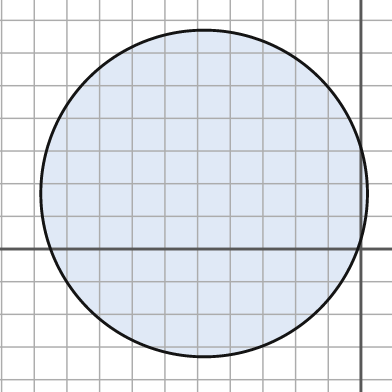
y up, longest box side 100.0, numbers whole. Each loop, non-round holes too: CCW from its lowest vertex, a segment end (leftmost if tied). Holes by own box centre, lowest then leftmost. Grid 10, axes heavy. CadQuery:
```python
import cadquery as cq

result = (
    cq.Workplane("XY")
    .moveTo(-48.0, 17.0)
    .circle(50.0)
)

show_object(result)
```